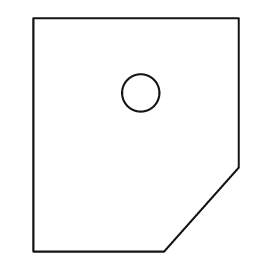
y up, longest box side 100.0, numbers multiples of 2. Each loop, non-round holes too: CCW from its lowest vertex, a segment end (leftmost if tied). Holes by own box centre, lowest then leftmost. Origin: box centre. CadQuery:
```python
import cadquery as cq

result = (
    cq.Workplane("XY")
    .moveTo(-44.0, -50.0)
    .lineTo(12.0, -50.0)
    .lineTo(44.0, -14.0)
    .lineTo(44.0, 50.0)
    .lineTo(-44.0, 50.0)
    .close()
    .moveTo(2.0, 18.0)
    .circle(8.0)
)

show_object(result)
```